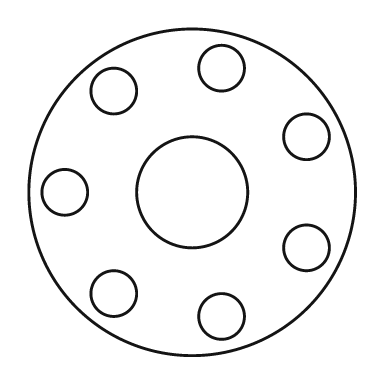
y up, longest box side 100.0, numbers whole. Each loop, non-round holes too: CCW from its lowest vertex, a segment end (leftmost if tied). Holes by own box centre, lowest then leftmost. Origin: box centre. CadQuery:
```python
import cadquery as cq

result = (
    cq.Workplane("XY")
    .moveTo(0.0, 0.0)
    .circle(50.0)
    .moveTo(9.0, -38.0)
    .circle(7.0)
    .moveTo(-24.0, -31.0)
    .circle(7.0)
    .moveTo(35.0, -17.0)
    .circle(7.0)
    .moveTo(-39.0, 0.0)
    .circle(7.0)
    .moveTo(0.0, 0.0)
    .circle(17.0)
    .moveTo(35.0, 17.0)
    .circle(7.0)
    .moveTo(-24.0, 31.0)
    .circle(7.0)
    .moveTo(9.0, 38.0)
    .circle(7.0)
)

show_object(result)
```